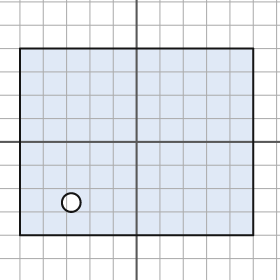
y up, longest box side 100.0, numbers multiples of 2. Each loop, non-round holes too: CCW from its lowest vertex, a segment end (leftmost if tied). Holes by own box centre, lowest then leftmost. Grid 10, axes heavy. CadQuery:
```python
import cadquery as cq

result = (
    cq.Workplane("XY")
    .moveTo(-50.0, -40.0)
    .lineTo(50.0, -40.0)
    .lineTo(50.0, 40.0)
    .lineTo(-50.0, 40.0)
    .close()
    .moveTo(-28.0, -26.0)
    .circle(4.0)
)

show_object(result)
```